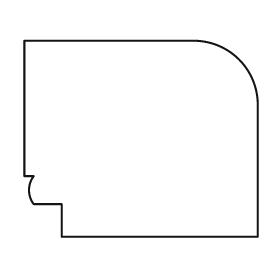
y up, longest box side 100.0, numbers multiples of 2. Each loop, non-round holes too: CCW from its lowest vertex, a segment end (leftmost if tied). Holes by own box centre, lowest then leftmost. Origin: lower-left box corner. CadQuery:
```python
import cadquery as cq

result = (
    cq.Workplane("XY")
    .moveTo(16.0, 0.0)
    .lineTo(100.0, 0.0)
    .lineTo(100.0, 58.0)
    .threePointArc((92.0, 76.0), (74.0, 84.0))
    .lineTo(0.0, 84.0)
    .lineTo(0.0, 26.0)
    .lineTo(4.0, 26.0)
    .threePointArc((2.0, 20.0), (4.0, 14.0))
    .lineTo(16.0, 14.0)
    .close()
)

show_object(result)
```